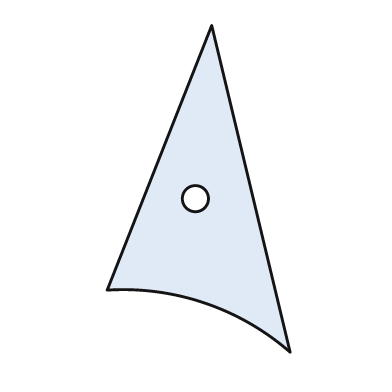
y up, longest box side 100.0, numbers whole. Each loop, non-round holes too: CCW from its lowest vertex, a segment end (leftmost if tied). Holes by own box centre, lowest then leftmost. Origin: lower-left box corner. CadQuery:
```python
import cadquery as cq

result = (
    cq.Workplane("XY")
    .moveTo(56.0, 0.0)
    .lineTo(32.0, 100.0)
    .lineTo(0.0, 19.0)
    .threePointArc((30.0, 15.0), (56.0, 0.0))
    .close()
    .moveTo(27.0, 47.0)
    .circle(4.0)
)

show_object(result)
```